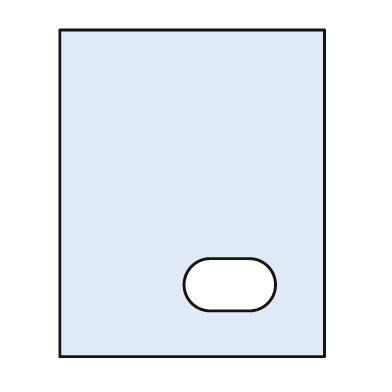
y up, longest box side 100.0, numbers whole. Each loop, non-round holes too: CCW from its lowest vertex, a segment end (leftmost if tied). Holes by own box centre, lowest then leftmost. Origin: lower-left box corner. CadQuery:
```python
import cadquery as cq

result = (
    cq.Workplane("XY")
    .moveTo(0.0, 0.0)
    .lineTo(81.0, 0.0)
    .lineTo(81.0, 100.0)
    .lineTo(0.0, 100.0)
    .close()
    .moveTo(46.0, 14.0)
    .lineTo(58.0, 14.0)
    .threePointArc((66.0, 22.0), (58.0, 30.0))
    .lineTo(46.0, 30.0)
    .threePointArc((38.0, 22.0), (46.0, 14.0))
    .close()
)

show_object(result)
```